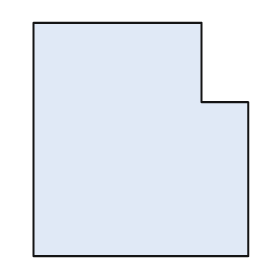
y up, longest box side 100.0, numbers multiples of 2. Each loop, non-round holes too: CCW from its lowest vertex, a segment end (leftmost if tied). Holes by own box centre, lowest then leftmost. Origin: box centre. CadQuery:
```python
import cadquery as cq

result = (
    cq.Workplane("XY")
    .moveTo(-46.0, -50.0)
    .lineTo(46.0, -50.0)
    .lineTo(46.0, 16.0)
    .lineTo(26.0, 16.0)
    .lineTo(26.0, 50.0)
    .lineTo(-46.0, 50.0)
    .close()
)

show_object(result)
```